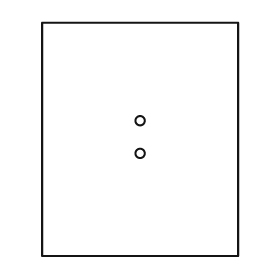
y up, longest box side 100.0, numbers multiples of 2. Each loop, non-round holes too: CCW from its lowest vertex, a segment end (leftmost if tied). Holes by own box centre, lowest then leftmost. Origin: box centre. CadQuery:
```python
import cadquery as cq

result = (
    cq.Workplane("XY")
    .moveTo(-42.0, -50.0)
    .lineTo(42.0, -50.0)
    .lineTo(42.0, 50.0)
    .lineTo(-42.0, 50.0)
    .close()
    .moveTo(0.0, -6.0)
    .circle(2.0)
    .moveTo(0.0, 8.0)
    .circle(2.0)
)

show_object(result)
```